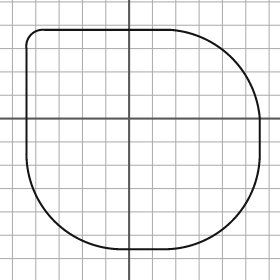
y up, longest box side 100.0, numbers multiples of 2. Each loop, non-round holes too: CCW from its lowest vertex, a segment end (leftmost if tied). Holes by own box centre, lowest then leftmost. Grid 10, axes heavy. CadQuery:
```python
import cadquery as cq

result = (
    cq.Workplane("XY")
    .moveTo(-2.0, -56.0)
    .lineTo(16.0, -56.0)
    .threePointArc((44.0, -44.0), (56.0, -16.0))
    .lineTo(56.0, 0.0)
    .threePointArc((44.0, 26.0), (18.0, 38.0))
    .lineTo(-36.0, 38.0)
    .threePointArc((-42.0, 36.0), (-44.0, 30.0))
    .lineTo(-44.0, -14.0)
    .threePointArc((-32.0, -44.0), (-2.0, -56.0))
    .close()
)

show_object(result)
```